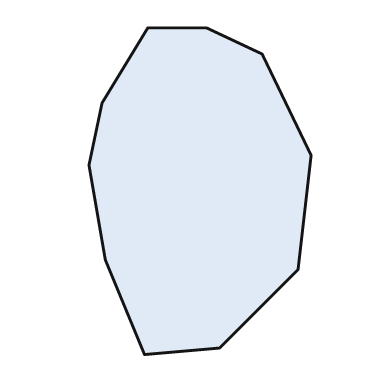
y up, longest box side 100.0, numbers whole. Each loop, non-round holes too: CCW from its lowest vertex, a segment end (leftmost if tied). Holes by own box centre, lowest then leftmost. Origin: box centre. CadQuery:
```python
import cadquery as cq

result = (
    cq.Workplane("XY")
    .moveTo(-17.0, -50.0)
    .lineTo(6.0, -48.0)
    .lineTo(30.0, -24.0)
    .lineTo(34.0, 11.0)
    .lineTo(19.0, 42.0)
    .lineTo(2.0, 50.0)
    .lineTo(-16.0, 50.0)
    .lineTo(-30.0, 27.0)
    .lineTo(-34.0, 8.0)
    .lineTo(-29.0, -21.0)
    .close()
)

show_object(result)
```